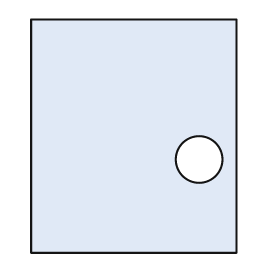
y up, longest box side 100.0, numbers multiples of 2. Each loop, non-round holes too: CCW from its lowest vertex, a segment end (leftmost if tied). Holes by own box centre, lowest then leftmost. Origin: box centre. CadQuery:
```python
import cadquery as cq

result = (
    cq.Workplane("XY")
    .moveTo(-44.0, -50.0)
    .lineTo(44.0, -50.0)
    .lineTo(44.0, 50.0)
    .lineTo(-44.0, 50.0)
    .close()
    .moveTo(28.0, -10.0)
    .circle(10.0)
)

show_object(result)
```